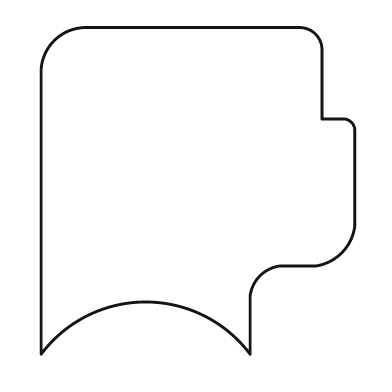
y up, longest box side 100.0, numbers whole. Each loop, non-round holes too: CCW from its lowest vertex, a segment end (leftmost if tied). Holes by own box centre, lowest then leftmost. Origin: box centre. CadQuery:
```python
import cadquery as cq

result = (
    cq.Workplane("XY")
    .moveTo(-48.0, -50.0)
    .threePointArc((-16.0, -34.0), (16.0, -50.0))
    .lineTo(16.0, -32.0)
    .threePointArc((19.0, -26.0), (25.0, -23.0))
    .lineTo(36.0, -23.0)
    .threePointArc((44.0, -19.0), (48.0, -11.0))
    .lineTo(48.0, 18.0)
    .threePointArc((47.0, 21.0), (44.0, 22.0))
    .lineTo(38.0, 22.0)
    .lineTo(38.0, 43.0)
    .threePointArc((36.0, 48.0), (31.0, 50.0))
    .lineTo(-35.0, 50.0)
    .threePointArc((-44.0, 46.0), (-48.0, 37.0))
    .close()
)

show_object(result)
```